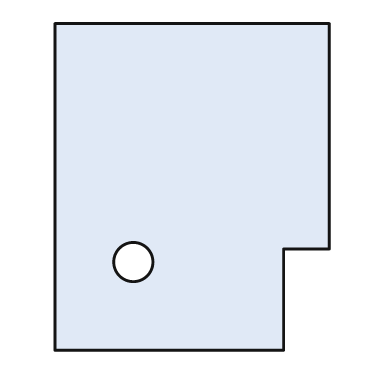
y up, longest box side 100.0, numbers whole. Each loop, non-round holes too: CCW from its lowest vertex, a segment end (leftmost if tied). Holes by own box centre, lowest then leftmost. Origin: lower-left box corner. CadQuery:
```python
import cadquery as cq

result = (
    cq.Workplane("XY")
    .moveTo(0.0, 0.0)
    .lineTo(70.0, 0.0)
    .lineTo(70.0, 31.0)
    .lineTo(84.0, 31.0)
    .lineTo(84.0, 100.0)
    .lineTo(0.0, 100.0)
    .close()
    .moveTo(24.0, 27.0)
    .circle(6.0)
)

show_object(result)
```